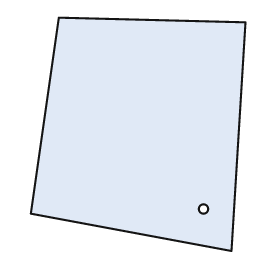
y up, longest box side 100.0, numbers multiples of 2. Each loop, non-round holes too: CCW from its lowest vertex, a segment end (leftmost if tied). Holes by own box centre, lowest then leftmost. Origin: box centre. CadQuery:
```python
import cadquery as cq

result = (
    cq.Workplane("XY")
    .moveTo(40.0, -50.0)
    .lineTo(46.0, 48.0)
    .lineTo(-34.0, 50.0)
    .lineTo(-46.0, -34.0)
    .close()
    .moveTo(28.0, -32.0)
    .circle(2.0)
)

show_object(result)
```